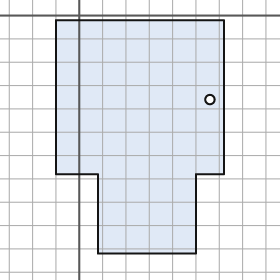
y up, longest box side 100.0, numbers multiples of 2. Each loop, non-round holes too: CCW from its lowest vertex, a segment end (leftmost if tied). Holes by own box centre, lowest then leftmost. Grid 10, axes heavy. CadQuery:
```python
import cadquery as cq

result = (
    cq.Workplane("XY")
    .moveTo(8.0, -102.0)
    .lineTo(50.0, -102.0)
    .lineTo(50.0, -68.0)
    .lineTo(62.0, -68.0)
    .lineTo(62.0, -2.0)
    .lineTo(-10.0, -2.0)
    .lineTo(-10.0, -68.0)
    .lineTo(8.0, -68.0)
    .close()
    .moveTo(56.0, -36.0)
    .circle(2.0)
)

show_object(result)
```